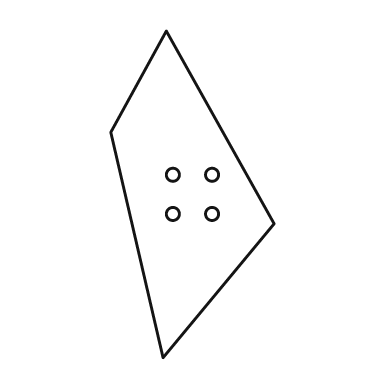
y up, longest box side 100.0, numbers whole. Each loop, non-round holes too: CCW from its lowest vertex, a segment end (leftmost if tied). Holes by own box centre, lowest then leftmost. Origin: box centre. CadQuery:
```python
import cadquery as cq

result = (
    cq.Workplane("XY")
    .moveTo(-9.0, -50.0)
    .lineTo(25.0, -9.0)
    .lineTo(-8.0, 50.0)
    .lineTo(-25.0, 19.0)
    .close()
    .moveTo(-6.0, -6.0)
    .circle(2.0)
    .moveTo(6.0, -6.0)
    .circle(2.0)
    .moveTo(-6.0, 6.0)
    .circle(2.0)
    .moveTo(6.0, 6.0)
    .circle(2.0)
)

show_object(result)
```